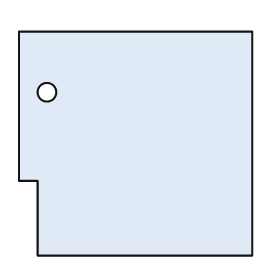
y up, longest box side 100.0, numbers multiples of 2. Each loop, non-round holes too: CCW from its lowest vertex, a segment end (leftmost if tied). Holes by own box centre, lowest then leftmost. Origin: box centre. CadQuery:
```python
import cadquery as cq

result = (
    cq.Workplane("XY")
    .moveTo(-42.0, -48.0)
    .lineTo(50.0, -48.0)
    .lineTo(50.0, 48.0)
    .lineTo(-50.0, 48.0)
    .lineTo(-50.0, -16.0)
    .lineTo(-42.0, -16.0)
    .close()
    .moveTo(-38.0, 22.0)
    .circle(4.0)
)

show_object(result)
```